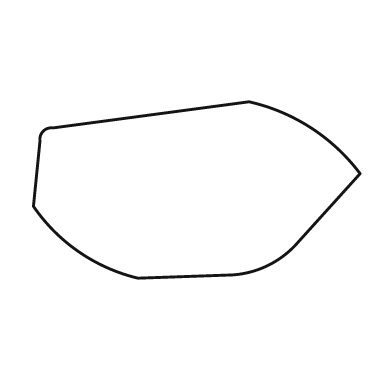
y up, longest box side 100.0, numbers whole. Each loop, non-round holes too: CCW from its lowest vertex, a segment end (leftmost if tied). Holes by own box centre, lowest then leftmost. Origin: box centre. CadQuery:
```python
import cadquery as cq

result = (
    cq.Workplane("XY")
    .moveTo(-18.0, -27.0)
    .lineTo(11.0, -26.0)
    .threePointArc((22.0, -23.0), (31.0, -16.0))
    .lineTo(50.0, 5.0)
    .threePointArc((35.0, 19.0), (16.0, 27.0))
    .lineTo(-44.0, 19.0)
    .threePointArc((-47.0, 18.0), (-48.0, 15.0))
    .lineTo(-50.0, -5.0)
    .threePointArc((-36.0, -19.0), (-18.0, -27.0))
    .close()
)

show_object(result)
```